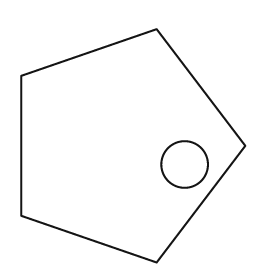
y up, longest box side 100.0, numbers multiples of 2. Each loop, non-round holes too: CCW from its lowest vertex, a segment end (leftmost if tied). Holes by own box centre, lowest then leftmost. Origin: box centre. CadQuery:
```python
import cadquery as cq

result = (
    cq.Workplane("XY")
    .moveTo(10.0, -50.0)
    .lineTo(48.0, 0.0)
    .lineTo(10.0, 50.0)
    .lineTo(-48.0, 30.0)
    .lineTo(-48.0, -30.0)
    .close()
    .moveTo(22.0, -8.0)
    .circle(10.0)
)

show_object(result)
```